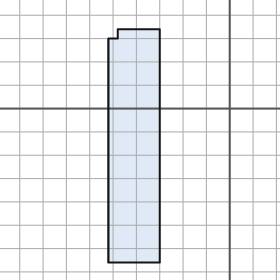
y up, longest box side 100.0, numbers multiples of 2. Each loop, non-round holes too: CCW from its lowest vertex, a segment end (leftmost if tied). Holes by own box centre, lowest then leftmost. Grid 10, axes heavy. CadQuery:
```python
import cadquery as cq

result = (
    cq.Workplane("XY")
    .moveTo(-52.0, -66.0)
    .lineTo(-30.0, -66.0)
    .lineTo(-30.0, 34.0)
    .lineTo(-48.0, 34.0)
    .lineTo(-48.0, 30.0)
    .lineTo(-52.0, 30.0)
    .close()
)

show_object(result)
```